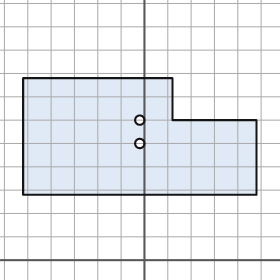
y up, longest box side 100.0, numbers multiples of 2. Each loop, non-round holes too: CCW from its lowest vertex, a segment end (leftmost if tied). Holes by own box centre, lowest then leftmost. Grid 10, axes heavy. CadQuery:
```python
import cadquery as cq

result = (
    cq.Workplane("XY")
    .moveTo(-52.0, 28.0)
    .lineTo(48.0, 28.0)
    .lineTo(48.0, 60.0)
    .lineTo(12.0, 60.0)
    .lineTo(12.0, 78.0)
    .lineTo(-52.0, 78.0)
    .close()
    .moveTo(-2.0, 50.0)
    .circle(2.0)
    .moveTo(-2.0, 60.0)
    .circle(2.0)
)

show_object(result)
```